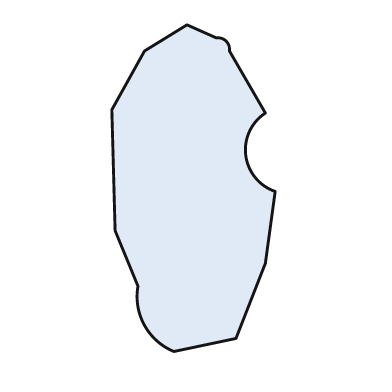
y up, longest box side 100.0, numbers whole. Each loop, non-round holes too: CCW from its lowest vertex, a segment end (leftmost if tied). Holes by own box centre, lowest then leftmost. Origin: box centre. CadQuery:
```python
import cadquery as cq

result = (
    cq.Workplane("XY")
    .moveTo(-6.0, -50.0)
    .lineTo(13.0, -46.0)
    .lineTo(22.0, -23.0)
    .lineTo(25.0, -1.0)
    .threePointArc((16.0, 10.0), (22.0, 23.0))
    .lineTo(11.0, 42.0)
    .threePointArc((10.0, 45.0), (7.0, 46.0))
    .lineTo(-2.0, 50.0)
    .lineTo(-15.0, 42.0)
    .lineTo(-25.0, 24.0)
    .lineTo(-24.0, -13.0)
    .lineTo(-17.0, -30.0)
    .threePointArc((-15.0, -42.0), (-6.0, -50.0))
    .close()
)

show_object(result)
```